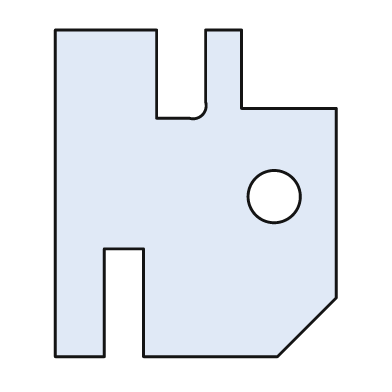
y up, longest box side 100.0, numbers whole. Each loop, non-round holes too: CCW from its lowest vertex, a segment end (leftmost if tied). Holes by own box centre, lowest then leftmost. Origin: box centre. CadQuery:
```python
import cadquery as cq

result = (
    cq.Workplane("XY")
    .moveTo(-43.0, -50.0)
    .lineTo(-28.0, -50.0)
    .lineTo(-28.0, -17.0)
    .lineTo(-16.0, -17.0)
    .lineTo(-16.0, -50.0)
    .lineTo(25.0, -50.0)
    .lineTo(43.0, -32.0)
    .lineTo(43.0, 26.0)
    .lineTo(14.0, 26.0)
    .lineTo(14.0, 50.0)
    .lineTo(3.0, 50.0)
    .lineTo(3.0, 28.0)
    .threePointArc((2.0, 24.0), (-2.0, 23.0))
    .lineTo(-12.0, 23.0)
    .lineTo(-12.0, 50.0)
    .lineTo(-43.0, 50.0)
    .close()
    .moveTo(24.0, -1.0)
    .circle(8.0)
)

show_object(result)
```